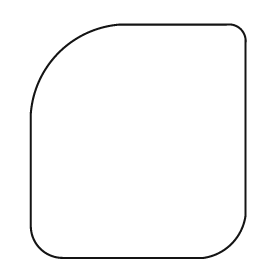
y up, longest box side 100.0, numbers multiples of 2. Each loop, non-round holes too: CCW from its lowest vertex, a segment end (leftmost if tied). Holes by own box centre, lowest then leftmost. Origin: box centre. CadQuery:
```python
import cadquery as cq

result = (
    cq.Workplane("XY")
    .moveTo(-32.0, -50.0)
    .lineTo(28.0, -50.0)
    .threePointArc((40.0, -44.0), (46.0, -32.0))
    .lineTo(46.0, 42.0)
    .threePointArc((44.0, 48.0), (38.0, 50.0))
    .lineTo(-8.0, 50.0)
    .threePointArc((-34.0, 38.0), (-46.0, 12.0))
    .lineTo(-46.0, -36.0)
    .threePointArc((-42.0, -46.0), (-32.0, -50.0))
    .close()
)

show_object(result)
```